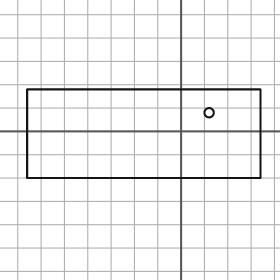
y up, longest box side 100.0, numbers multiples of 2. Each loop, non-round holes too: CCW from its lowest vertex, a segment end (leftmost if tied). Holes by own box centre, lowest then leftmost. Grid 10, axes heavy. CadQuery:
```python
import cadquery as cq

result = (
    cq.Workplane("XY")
    .moveTo(-66.0, -20.0)
    .lineTo(34.0, -20.0)
    .lineTo(34.0, 18.0)
    .lineTo(-66.0, 18.0)
    .close()
    .moveTo(12.0, 8.0)
    .circle(2.0)
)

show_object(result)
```